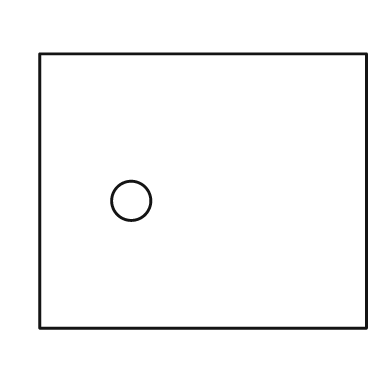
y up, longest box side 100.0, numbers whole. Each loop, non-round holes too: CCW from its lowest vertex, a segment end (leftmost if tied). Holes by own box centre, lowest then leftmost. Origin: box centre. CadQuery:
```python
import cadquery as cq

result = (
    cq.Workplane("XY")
    .moveTo(-50.0, -42.0)
    .lineTo(50.0, -42.0)
    .lineTo(50.0, 42.0)
    .lineTo(-50.0, 42.0)
    .close()
    .moveTo(-22.0, -3.0)
    .circle(6.0)
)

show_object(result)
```